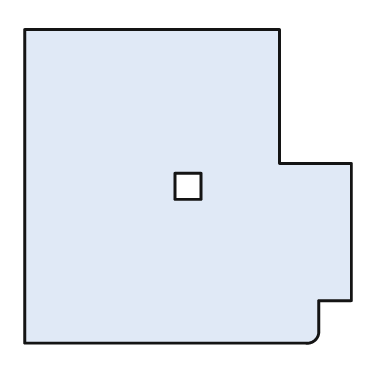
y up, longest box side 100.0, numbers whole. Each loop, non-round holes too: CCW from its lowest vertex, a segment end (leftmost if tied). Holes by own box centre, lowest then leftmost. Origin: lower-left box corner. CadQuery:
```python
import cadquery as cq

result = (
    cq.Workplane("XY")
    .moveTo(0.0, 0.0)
    .lineTo(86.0, 0.0)
    .threePointArc((89.0, 1.0), (90.0, 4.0))
    .lineTo(90.0, 13.0)
    .lineTo(100.0, 13.0)
    .lineTo(100.0, 55.0)
    .lineTo(78.0, 55.0)
    .lineTo(78.0, 96.0)
    .lineTo(0.0, 96.0)
    .close()
    .moveTo(46.0, 44.0)
    .lineTo(54.0, 44.0)
    .lineTo(54.0, 52.0)
    .lineTo(46.0, 52.0)
    .close()
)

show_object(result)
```